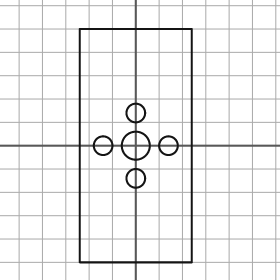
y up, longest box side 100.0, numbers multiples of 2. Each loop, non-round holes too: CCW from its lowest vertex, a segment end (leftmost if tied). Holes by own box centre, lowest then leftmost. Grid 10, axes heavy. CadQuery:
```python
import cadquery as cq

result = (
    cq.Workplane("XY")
    .moveTo(-24.0, -50.0)
    .lineTo(24.0, -50.0)
    .lineTo(24.0, 50.0)
    .lineTo(-24.0, 50.0)
    .close()
    .moveTo(0.0, -14.0)
    .circle(4.0)
    .moveTo(-14.0, 0.0)
    .circle(4.0)
    .moveTo(0.0, 0.0)
    .circle(6.0)
    .moveTo(14.0, 0.0)
    .circle(4.0)
    .moveTo(0.0, 14.0)
    .circle(4.0)
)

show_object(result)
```